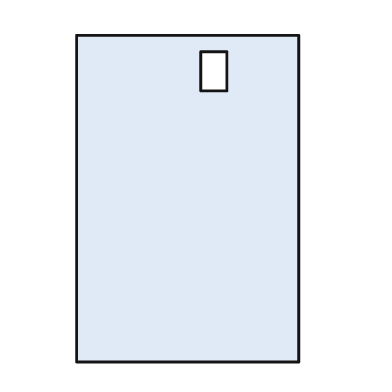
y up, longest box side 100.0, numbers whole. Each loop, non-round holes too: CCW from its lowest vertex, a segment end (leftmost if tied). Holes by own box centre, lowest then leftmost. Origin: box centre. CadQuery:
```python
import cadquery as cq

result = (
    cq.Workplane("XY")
    .moveTo(-34.0, -50.0)
    .lineTo(34.0, -50.0)
    .lineTo(34.0, 50.0)
    .lineTo(-34.0, 50.0)
    .close()
    .moveTo(4.0, 33.0)
    .lineTo(12.0, 33.0)
    .lineTo(12.0, 45.0)
    .lineTo(4.0, 45.0)
    .close()
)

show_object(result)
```